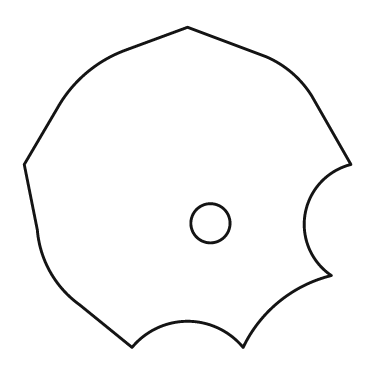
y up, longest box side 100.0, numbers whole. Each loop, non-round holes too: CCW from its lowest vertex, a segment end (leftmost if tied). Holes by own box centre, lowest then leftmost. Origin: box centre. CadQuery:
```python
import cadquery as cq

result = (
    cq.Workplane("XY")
    .moveTo(-17.0, -49.0)
    .threePointArc((0.0, -41.0), (17.0, -49.0))
    .threePointArc((28.0, -35.0), (44.0, -27.0))
    .threePointArc((36.0, -8.0), (50.0, 7.0))
    .lineTo(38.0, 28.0)
    .threePointArc((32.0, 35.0), (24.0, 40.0))
    .lineTo(0.0, 49.0)
    .lineTo(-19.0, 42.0)
    .threePointArc((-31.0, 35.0), (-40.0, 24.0))
    .lineTo(-50.0, 7.0)
    .lineTo(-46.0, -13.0)
    .threePointArc((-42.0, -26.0), (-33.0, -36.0))
    .close()
    .moveTo(7.0, -11.0)
    .circle(6.0)
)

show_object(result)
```